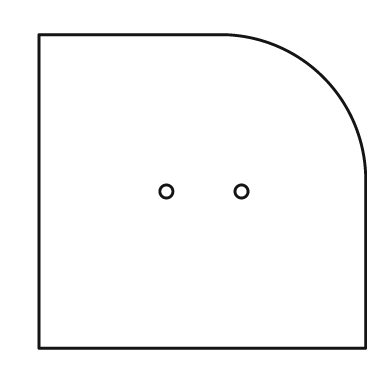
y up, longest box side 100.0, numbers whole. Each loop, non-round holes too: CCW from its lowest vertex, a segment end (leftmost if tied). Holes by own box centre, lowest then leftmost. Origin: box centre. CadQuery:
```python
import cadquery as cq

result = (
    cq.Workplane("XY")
    .moveTo(-50.0, -48.0)
    .lineTo(50.0, -48.0)
    .lineTo(50.0, 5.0)
    .threePointArc((37.0, 35.0), (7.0, 48.0))
    .lineTo(-50.0, 48.0)
    .close()
    .moveTo(-11.0, 0.0)
    .circle(2.0)
    .moveTo(12.0, 0.0)
    .circle(2.0)
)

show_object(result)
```